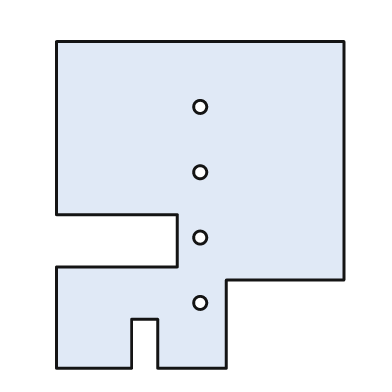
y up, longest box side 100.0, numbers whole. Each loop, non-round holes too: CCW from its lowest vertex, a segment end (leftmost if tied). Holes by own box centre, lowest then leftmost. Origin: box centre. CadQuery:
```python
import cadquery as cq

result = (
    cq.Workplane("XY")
    .moveTo(-44.0, -50.0)
    .lineTo(-21.0, -50.0)
    .lineTo(-21.0, -35.0)
    .lineTo(-13.0, -35.0)
    .lineTo(-13.0, -50.0)
    .lineTo(8.0, -50.0)
    .lineTo(8.0, -23.0)
    .lineTo(44.0, -23.0)
    .lineTo(44.0, 50.0)
    .lineTo(-44.0, 50.0)
    .lineTo(-44.0, -3.0)
    .lineTo(-7.0, -3.0)
    .lineTo(-7.0, -19.0)
    .lineTo(-44.0, -19.0)
    .close()
    .moveTo(0.0, -30.0)
    .circle(2.0)
    .moveTo(0.0, -10.0)
    .circle(2.0)
    .moveTo(0.0, 10.0)
    .circle(2.0)
    .moveTo(0.0, 30.0)
    .circle(2.0)
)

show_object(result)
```